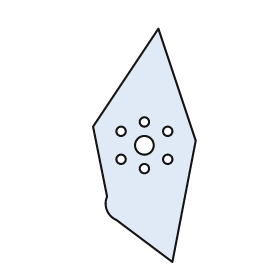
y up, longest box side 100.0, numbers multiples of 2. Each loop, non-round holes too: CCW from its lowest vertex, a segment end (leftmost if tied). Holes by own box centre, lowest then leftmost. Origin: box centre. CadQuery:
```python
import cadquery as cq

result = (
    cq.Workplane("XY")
    .moveTo(12.0, -50.0)
    .lineTo(22.0, 2.0)
    .lineTo(6.0, 50.0)
    .lineTo(-22.0, 8.0)
    .lineTo(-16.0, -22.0)
    .threePointArc((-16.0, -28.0), (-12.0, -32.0))
    .close()
    .moveTo(0.0, -10.0)
    .circle(2.0)
    .moveTo(-10.0, -6.0)
    .circle(2.0)
    .moveTo(10.0, -6.0)
    .circle(2.0)
    .moveTo(0.0, 0.0)
    .circle(4.0)
    .moveTo(-10.0, 6.0)
    .circle(2.0)
    .moveTo(10.0, 6.0)
    .circle(2.0)
    .moveTo(0.0, 10.0)
    .circle(2.0)
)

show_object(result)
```